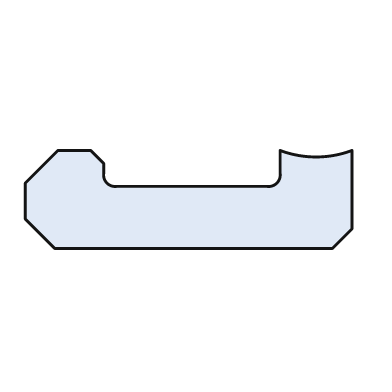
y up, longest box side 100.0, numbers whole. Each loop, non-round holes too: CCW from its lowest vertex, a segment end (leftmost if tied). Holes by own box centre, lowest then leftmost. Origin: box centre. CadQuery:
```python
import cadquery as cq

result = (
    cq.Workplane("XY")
    .moveTo(-41.0, -15.0)
    .lineTo(44.0, -15.0)
    .lineTo(50.0, -9.0)
    .lineTo(50.0, 15.0)
    .threePointArc((39.0, 13.0), (28.0, 15.0))
    .lineTo(28.0, 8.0)
    .threePointArc((27.0, 5.0), (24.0, 4.0))
    .lineTo(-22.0, 4.0)
    .threePointArc((-25.0, 5.0), (-26.0, 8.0))
    .lineTo(-26.0, 11.0)
    .lineTo(-30.0, 15.0)
    .lineTo(-40.0, 15.0)
    .lineTo(-50.0, 5.0)
    .lineTo(-50.0, -6.0)
    .close()
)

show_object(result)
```